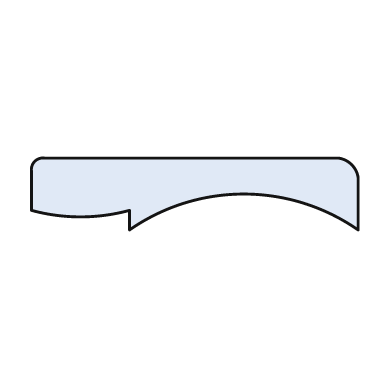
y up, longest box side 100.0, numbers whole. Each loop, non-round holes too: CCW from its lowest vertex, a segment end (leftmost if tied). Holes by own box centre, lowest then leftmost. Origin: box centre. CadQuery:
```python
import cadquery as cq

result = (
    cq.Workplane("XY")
    .moveTo(-20.0, -11.0)
    .threePointArc((15.0, 0.0), (50.0, -11.0))
    .lineTo(50.0, 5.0)
    .threePointArc((48.0, 9.0), (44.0, 11.0))
    .lineTo(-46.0, 11.0)
    .threePointArc((-49.0, 10.0), (-50.0, 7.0))
    .lineTo(-50.0, -5.0)
    .threePointArc((-35.0, -7.0), (-20.0, -5.0))
    .close()
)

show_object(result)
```